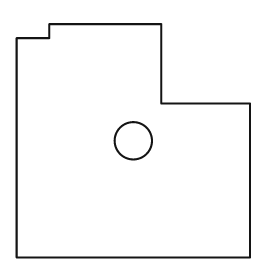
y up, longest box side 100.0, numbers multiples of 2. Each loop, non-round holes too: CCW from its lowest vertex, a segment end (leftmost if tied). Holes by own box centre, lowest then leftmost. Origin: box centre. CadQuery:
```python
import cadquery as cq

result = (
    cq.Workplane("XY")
    .moveTo(-50.0, -50.0)
    .lineTo(50.0, -50.0)
    .lineTo(50.0, 16.0)
    .lineTo(12.0, 16.0)
    .lineTo(12.0, 50.0)
    .lineTo(-36.0, 50.0)
    .lineTo(-36.0, 44.0)
    .lineTo(-50.0, 44.0)
    .close()
    .moveTo(0.0, 0.0)
    .circle(8.0)
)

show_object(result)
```